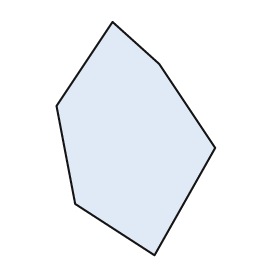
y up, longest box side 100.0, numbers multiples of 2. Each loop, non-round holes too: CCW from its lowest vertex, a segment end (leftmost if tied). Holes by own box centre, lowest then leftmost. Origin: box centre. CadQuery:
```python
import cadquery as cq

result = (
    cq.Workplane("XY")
    .moveTo(8.0, -50.0)
    .lineTo(34.0, -4.0)
    .lineTo(10.0, 32.0)
    .lineTo(-10.0, 50.0)
    .lineTo(-34.0, 14.0)
    .lineTo(-26.0, -28.0)
    .close()
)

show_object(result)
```